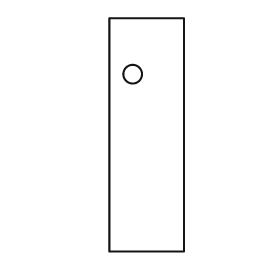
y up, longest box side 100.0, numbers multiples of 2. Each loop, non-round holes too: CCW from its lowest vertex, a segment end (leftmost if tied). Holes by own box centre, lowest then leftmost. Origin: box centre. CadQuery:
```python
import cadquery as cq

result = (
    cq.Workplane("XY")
    .moveTo(-16.0, -50.0)
    .lineTo(16.0, -50.0)
    .lineTo(16.0, 50.0)
    .lineTo(-16.0, 50.0)
    .close()
    .moveTo(-6.0, 26.0)
    .circle(4.0)
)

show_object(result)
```